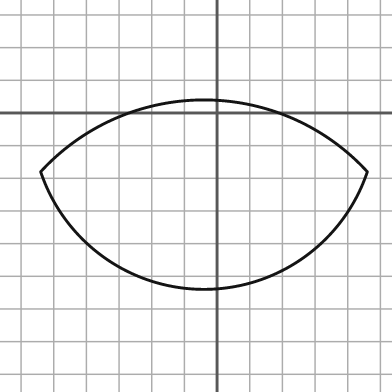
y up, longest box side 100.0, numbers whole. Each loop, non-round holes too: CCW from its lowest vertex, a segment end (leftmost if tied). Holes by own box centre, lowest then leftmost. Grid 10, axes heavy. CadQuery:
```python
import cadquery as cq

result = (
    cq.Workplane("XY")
    .moveTo(-54.0, -18.0)
    .threePointArc((-4.0, -54.0), (46.0, -18.0))
    .threePointArc((-4.0, 4.0), (-54.0, -18.0))
    .close()
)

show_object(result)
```